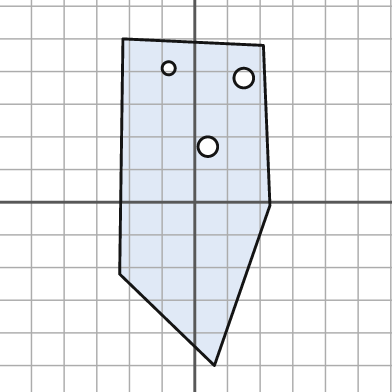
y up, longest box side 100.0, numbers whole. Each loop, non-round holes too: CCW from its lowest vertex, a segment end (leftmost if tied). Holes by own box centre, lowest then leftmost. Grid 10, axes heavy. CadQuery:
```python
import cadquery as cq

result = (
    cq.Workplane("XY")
    .moveTo(6.0, -50.0)
    .lineTo(23.0, -1.0)
    .lineTo(21.0, 48.0)
    .lineTo(-22.0, 50.0)
    .lineTo(-23.0, -22.0)
    .close()
    .moveTo(4.0, 17.0)
    .circle(3.0)
    .moveTo(15.0, 38.0)
    .circle(3.0)
    .moveTo(-8.0, 41.0)
    .circle(2.0)
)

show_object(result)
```